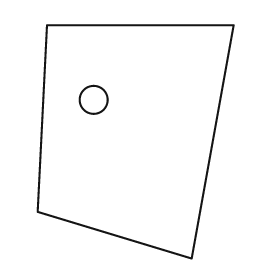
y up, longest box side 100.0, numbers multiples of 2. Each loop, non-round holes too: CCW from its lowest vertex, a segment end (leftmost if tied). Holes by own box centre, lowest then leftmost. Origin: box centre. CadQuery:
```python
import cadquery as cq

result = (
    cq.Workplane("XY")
    .moveTo(24.0, -50.0)
    .lineTo(42.0, 50.0)
    .lineTo(-38.0, 50.0)
    .lineTo(-42.0, -30.0)
    .close()
    .moveTo(-18.0, 18.0)
    .circle(6.0)
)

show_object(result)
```